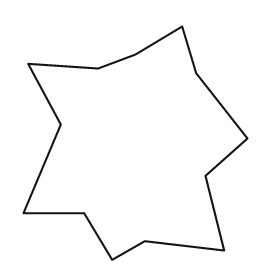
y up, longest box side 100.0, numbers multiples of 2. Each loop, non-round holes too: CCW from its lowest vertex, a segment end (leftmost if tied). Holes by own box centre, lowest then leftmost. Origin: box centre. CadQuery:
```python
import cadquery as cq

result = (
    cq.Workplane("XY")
    .moveTo(-10.0, -50.0)
    .lineTo(4.0, -42.0)
    .lineTo(38.0, -46.0)
    .lineTo(30.0, -14.0)
    .lineTo(48.0, 2.0)
    .lineTo(26.0, 30.0)
    .lineTo(20.0, 50.0)
    .lineTo(0.0, 38.0)
    .lineTo(-16.0, 32.0)
    .lineTo(-46.0, 34.0)
    .lineTo(-32.0, 8.0)
    .lineTo(-48.0, -30.0)
    .lineTo(-22.0, -30.0)
    .close()
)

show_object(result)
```